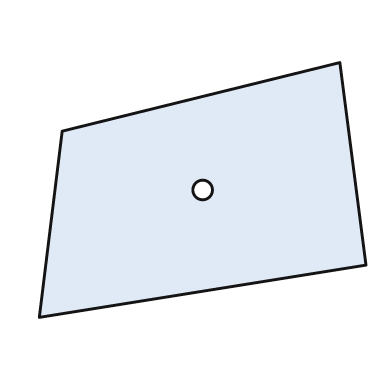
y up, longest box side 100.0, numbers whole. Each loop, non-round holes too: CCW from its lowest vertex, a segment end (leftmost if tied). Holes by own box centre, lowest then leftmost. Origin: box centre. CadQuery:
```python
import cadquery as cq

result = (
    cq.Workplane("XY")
    .moveTo(-50.0, -39.0)
    .lineTo(50.0, -23.0)
    .lineTo(42.0, 39.0)
    .lineTo(-43.0, 18.0)
    .close()
    .moveTo(0.0, 0.0)
    .circle(3.0)
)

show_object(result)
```